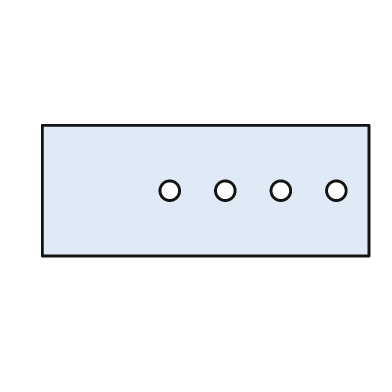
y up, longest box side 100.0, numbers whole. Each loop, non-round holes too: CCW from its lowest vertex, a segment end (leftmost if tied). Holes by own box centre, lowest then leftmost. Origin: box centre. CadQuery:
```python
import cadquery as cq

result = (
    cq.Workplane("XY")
    .moveTo(-50.0, -20.0)
    .lineTo(50.0, -20.0)
    .lineTo(50.0, 20.0)
    .lineTo(-50.0, 20.0)
    .close()
    .moveTo(-11.0, 0.0)
    .circle(3.0)
    .moveTo(6.0, 0.0)
    .circle(3.0)
    .moveTo(23.0, 0.0)
    .circle(3.0)
    .moveTo(40.0, 0.0)
    .circle(3.0)
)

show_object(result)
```